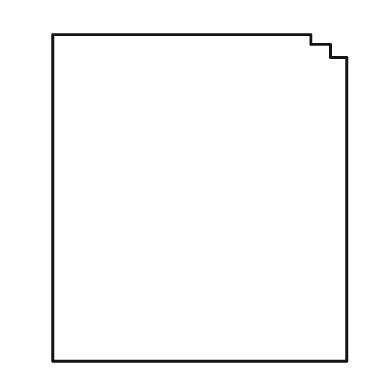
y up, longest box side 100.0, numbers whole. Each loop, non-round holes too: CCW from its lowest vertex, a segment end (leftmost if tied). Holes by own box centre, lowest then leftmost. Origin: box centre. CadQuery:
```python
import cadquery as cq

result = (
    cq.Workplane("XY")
    .moveTo(-45.0, -50.0)
    .lineTo(45.0, -50.0)
    .lineTo(45.0, 43.0)
    .lineTo(40.0, 43.0)
    .lineTo(40.0, 47.0)
    .lineTo(34.0, 47.0)
    .lineTo(34.0, 50.0)
    .lineTo(-45.0, 50.0)
    .close()
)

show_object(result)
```